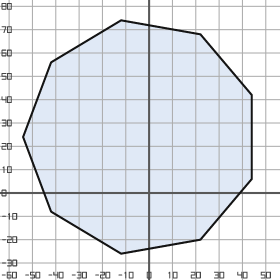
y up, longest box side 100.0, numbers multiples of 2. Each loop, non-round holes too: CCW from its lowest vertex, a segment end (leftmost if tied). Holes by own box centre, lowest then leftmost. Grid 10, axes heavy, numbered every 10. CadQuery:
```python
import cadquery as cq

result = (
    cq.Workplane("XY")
    .moveTo(-12.0, -26.0)
    .lineTo(22.0, -20.0)
    .lineTo(44.0, 6.0)
    .lineTo(44.0, 42.0)
    .lineTo(22.0, 68.0)
    .lineTo(-12.0, 74.0)
    .lineTo(-42.0, 56.0)
    .lineTo(-54.0, 24.0)
    .lineTo(-42.0, -8.0)
    .close()
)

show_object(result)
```